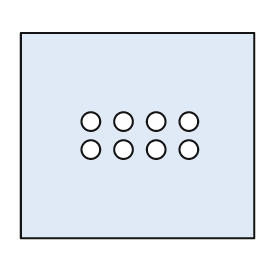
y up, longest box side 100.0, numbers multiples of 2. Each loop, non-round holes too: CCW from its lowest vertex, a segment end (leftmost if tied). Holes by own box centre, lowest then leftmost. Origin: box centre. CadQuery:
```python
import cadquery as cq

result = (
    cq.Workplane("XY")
    .moveTo(-50.0, -44.0)
    .lineTo(50.0, -44.0)
    .lineTo(50.0, 44.0)
    .lineTo(-50.0, 44.0)
    .close()
    .moveTo(-20.0, -6.0)
    .circle(4.0)
    .moveTo(-6.0, -6.0)
    .circle(4.0)
    .moveTo(8.0, -6.0)
    .circle(4.0)
    .moveTo(22.0, -6.0)
    .circle(4.0)
    .moveTo(-20.0, 6.0)
    .circle(4.0)
    .moveTo(-6.0, 6.0)
    .circle(4.0)
    .moveTo(8.0, 6.0)
    .circle(4.0)
    .moveTo(22.0, 6.0)
    .circle(4.0)
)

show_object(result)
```